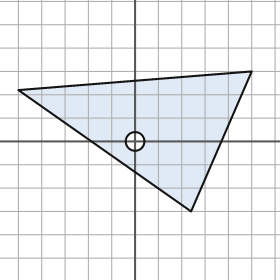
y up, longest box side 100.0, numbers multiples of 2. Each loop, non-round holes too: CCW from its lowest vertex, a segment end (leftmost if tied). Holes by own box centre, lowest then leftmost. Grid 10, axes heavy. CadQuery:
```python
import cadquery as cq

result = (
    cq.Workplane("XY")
    .moveTo(24.0, -30.0)
    .lineTo(50.0, 30.0)
    .lineTo(-50.0, 22.0)
    .close()
    .moveTo(0.0, 0.0)
    .circle(4.0)
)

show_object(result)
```